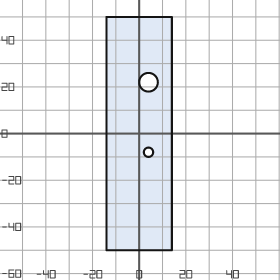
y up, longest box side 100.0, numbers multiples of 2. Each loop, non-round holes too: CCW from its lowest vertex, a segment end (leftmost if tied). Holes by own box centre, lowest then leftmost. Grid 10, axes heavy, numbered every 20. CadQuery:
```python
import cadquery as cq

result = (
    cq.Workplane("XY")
    .moveTo(-14.0, -50.0)
    .lineTo(14.0, -50.0)
    .lineTo(14.0, 50.0)
    .lineTo(-14.0, 50.0)
    .close()
    .moveTo(4.0, -8.0)
    .circle(2.0)
    .moveTo(4.0, 22.0)
    .circle(4.0)
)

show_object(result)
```